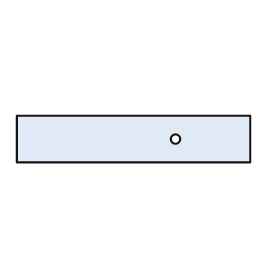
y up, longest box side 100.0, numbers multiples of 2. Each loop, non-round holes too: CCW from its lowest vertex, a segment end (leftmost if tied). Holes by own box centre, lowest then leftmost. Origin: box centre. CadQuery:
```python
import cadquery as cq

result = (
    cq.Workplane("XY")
    .moveTo(-50.0, -10.0)
    .lineTo(50.0, -10.0)
    .lineTo(50.0, 10.0)
    .lineTo(-50.0, 10.0)
    .close()
    .moveTo(18.0, 0.0)
    .circle(2.0)
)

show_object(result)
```